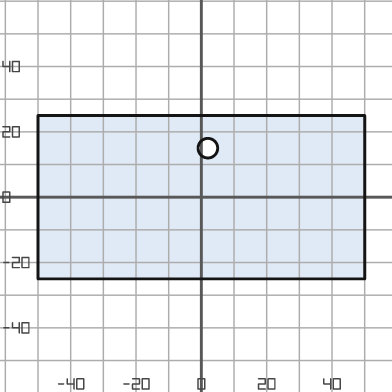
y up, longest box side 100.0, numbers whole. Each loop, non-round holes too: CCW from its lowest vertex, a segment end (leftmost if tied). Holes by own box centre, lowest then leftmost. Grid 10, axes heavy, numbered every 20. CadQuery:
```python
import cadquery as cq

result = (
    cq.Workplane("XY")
    .moveTo(-50.0, -25.0)
    .lineTo(50.0, -25.0)
    .lineTo(50.0, 25.0)
    .lineTo(-50.0, 25.0)
    .close()
    .moveTo(2.0, 15.0)
    .circle(3.0)
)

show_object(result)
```